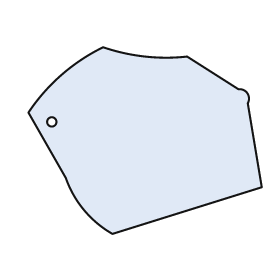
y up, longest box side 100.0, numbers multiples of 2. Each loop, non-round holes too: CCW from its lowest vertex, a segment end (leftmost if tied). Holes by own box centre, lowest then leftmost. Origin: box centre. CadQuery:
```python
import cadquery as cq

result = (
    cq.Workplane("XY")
    .moveTo(-14.0, -40.0)
    .lineTo(50.0, -20.0)
    .lineTo(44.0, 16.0)
    .threePointArc((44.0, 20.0), (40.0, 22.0))
    .lineTo(18.0, 36.0)
    .threePointArc((0.0, 36.0), (-18.0, 40.0))
    .threePointArc((-36.0, 28.0), (-50.0, 12.0))
    .lineTo(-34.0, -16.0)
    .threePointArc((-26.0, -30.0), (-14.0, -40.0))
    .close()
    .moveTo(-40.0, 8.0)
    .circle(2.0)
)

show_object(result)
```